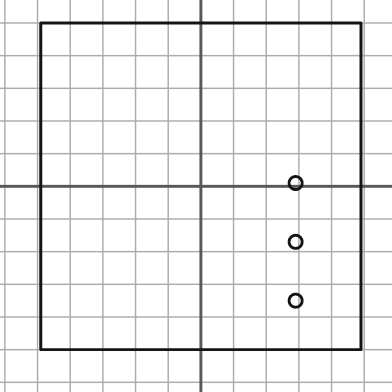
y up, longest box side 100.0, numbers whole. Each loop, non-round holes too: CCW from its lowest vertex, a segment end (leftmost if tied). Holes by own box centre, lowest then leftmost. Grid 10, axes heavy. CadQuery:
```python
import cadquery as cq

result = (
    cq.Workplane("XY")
    .moveTo(-49.0, -50.0)
    .lineTo(49.0, -50.0)
    .lineTo(49.0, 50.0)
    .lineTo(-49.0, 50.0)
    .close()
    .moveTo(29.0, -35.0)
    .circle(2.0)
    .moveTo(29.0, -17.0)
    .circle(2.0)
    .moveTo(29.0, 1.0)
    .circle(2.0)
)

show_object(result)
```